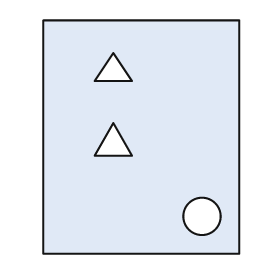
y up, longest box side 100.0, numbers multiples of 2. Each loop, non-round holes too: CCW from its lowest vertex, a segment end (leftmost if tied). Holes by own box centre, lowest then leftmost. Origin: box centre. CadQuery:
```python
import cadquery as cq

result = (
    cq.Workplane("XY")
    .moveTo(-42.0, -50.0)
    .lineTo(42.0, -50.0)
    .lineTo(42.0, 50.0)
    .lineTo(-42.0, 50.0)
    .close()
    .moveTo(26.0, -34.0)
    .circle(8.0)
    .moveTo(-20.0, -8.0)
    .lineTo(-4.0, -8.0)
    .lineTo(-12.0, 6.0)
    .close()
    .moveTo(-20.0, 24.0)
    .lineTo(-4.0, 24.0)
    .lineTo(-12.0, 36.0)
    .close()
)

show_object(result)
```